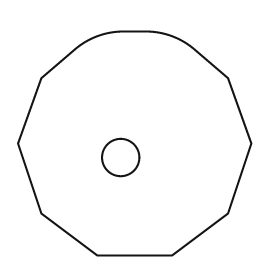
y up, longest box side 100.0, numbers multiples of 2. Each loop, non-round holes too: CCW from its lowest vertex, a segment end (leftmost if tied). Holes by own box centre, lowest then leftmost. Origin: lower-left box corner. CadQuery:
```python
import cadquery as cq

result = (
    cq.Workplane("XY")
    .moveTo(34.0, 0.0)
    .lineTo(66.0, 0.0)
    .lineTo(90.0, 18.0)
    .lineTo(100.0, 48.0)
    .lineTo(90.0, 76.0)
    .lineTo(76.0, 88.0)
    .threePointArc((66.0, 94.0), (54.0, 96.0))
    .lineTo(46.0, 96.0)
    .threePointArc((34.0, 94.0), (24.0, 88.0))
    .lineTo(10.0, 76.0)
    .lineTo(0.0, 48.0)
    .lineTo(10.0, 18.0)
    .close()
    .moveTo(44.0, 42.0)
    .circle(8.0)
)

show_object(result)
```